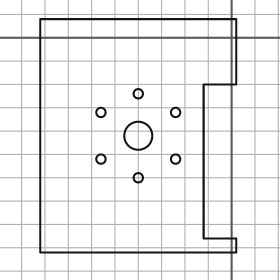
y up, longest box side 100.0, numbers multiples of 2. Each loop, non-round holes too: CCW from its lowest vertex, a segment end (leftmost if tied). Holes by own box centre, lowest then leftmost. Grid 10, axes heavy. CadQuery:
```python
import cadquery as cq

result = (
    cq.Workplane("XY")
    .moveTo(-82.0, -92.0)
    .lineTo(2.0, -92.0)
    .lineTo(2.0, -86.0)
    .lineTo(-12.0, -86.0)
    .lineTo(-12.0, -20.0)
    .lineTo(2.0, -20.0)
    .lineTo(2.0, 8.0)
    .lineTo(-82.0, 8.0)
    .close()
    .moveTo(-40.0, -60.0)
    .circle(2.0)
    .moveTo(-56.0, -52.0)
    .circle(2.0)
    .moveTo(-24.0, -52.0)
    .circle(2.0)
    .moveTo(-40.0, -42.0)
    .circle(6.0)
    .moveTo(-56.0, -32.0)
    .circle(2.0)
    .moveTo(-24.0, -32.0)
    .circle(2.0)
    .moveTo(-40.0, -24.0)
    .circle(2.0)
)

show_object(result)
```